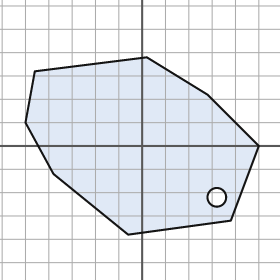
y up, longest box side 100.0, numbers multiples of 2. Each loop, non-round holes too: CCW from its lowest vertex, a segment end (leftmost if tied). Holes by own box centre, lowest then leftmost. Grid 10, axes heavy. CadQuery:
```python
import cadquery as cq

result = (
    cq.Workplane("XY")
    .moveTo(-6.0, -38.0)
    .lineTo(38.0, -32.0)
    .lineTo(50.0, 0.0)
    .lineTo(28.0, 22.0)
    .lineTo(2.0, 38.0)
    .lineTo(-46.0, 32.0)
    .lineTo(-50.0, 10.0)
    .lineTo(-38.0, -12.0)
    .close()
    .moveTo(32.0, -22.0)
    .circle(4.0)
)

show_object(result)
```